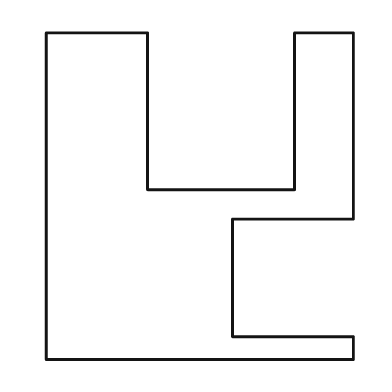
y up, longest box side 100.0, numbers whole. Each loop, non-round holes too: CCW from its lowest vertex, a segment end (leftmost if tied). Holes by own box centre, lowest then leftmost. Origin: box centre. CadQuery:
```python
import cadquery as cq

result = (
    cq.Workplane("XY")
    .moveTo(-47.0, -50.0)
    .lineTo(47.0, -50.0)
    .lineTo(47.0, -43.0)
    .lineTo(10.0, -43.0)
    .lineTo(10.0, -7.0)
    .lineTo(47.0, -7.0)
    .lineTo(47.0, 50.0)
    .lineTo(29.0, 50.0)
    .lineTo(29.0, 2.0)
    .lineTo(-16.0, 2.0)
    .lineTo(-16.0, 50.0)
    .lineTo(-47.0, 50.0)
    .close()
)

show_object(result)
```